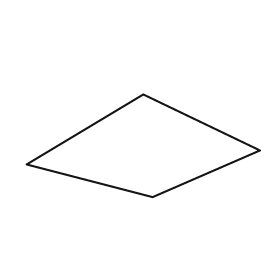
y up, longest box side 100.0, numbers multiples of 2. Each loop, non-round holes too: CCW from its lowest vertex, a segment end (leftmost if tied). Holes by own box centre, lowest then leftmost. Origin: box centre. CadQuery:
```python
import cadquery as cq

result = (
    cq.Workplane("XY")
    .moveTo(4.0, -22.0)
    .lineTo(50.0, -2.0)
    .lineTo(0.0, 22.0)
    .lineTo(-50.0, -8.0)
    .close()
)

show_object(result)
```